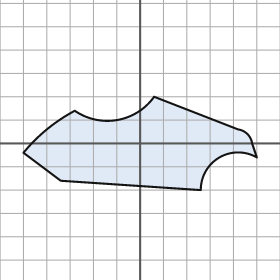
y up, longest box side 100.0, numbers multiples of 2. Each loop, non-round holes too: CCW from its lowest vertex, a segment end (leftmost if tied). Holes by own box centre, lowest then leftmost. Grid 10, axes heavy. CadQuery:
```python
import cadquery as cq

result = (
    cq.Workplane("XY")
    .moveTo(26.0, -20.0)
    .threePointArc((34.0, -6.0), (50.0, -6.0))
    .lineTo(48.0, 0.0)
    .threePointArc((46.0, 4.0), (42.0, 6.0))
    .lineTo(6.0, 20.0)
    .threePointArc((-10.0, 10.0), (-28.0, 14.0))
    .threePointArc((-40.0, 6.0), (-50.0, -4.0))
    .lineTo(-34.0, -16.0)
    .close()
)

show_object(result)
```